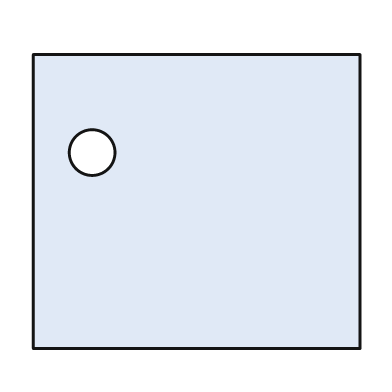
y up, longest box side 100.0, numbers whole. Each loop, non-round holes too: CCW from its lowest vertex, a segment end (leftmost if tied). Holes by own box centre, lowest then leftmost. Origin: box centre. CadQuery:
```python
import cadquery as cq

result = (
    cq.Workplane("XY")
    .moveTo(-50.0, -45.0)
    .lineTo(50.0, -45.0)
    .lineTo(50.0, 45.0)
    .lineTo(-50.0, 45.0)
    .close()
    .moveTo(-32.0, 15.0)
    .circle(7.0)
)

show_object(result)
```